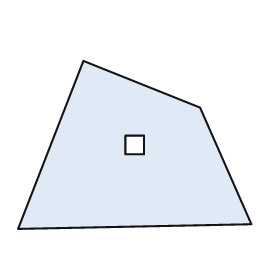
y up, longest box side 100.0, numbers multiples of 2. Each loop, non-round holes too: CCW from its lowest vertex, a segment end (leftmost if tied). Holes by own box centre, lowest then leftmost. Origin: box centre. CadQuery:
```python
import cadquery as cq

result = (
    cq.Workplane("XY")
    .moveTo(-50.0, -36.0)
    .lineTo(50.0, -34.0)
    .lineTo(28.0, 16.0)
    .lineTo(-22.0, 36.0)
    .close()
    .moveTo(-4.0, -4.0)
    .lineTo(4.0, -4.0)
    .lineTo(4.0, 4.0)
    .lineTo(-4.0, 4.0)
    .close()
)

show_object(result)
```